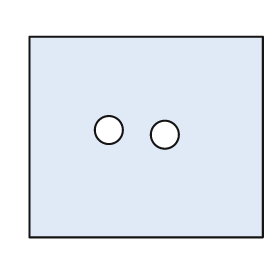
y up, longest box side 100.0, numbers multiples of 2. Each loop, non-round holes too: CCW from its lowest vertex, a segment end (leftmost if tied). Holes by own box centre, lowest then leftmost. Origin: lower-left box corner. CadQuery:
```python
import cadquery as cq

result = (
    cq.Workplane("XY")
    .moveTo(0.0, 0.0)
    .lineTo(100.0, 0.0)
    .lineTo(100.0, 86.0)
    .lineTo(0.0, 86.0)
    .close()
    .moveTo(58.0, 44.0)
    .circle(6.0)
    .moveTo(34.0, 46.0)
    .circle(6.0)
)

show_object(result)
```